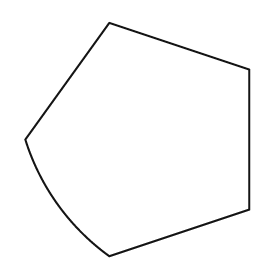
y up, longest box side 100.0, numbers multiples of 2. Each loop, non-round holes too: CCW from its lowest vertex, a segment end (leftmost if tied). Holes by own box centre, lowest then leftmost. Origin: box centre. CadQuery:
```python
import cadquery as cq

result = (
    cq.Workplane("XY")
    .moveTo(-12.0, -50.0)
    .lineTo(48.0, -30.0)
    .lineTo(48.0, 30.0)
    .lineTo(-12.0, 50.0)
    .lineTo(-48.0, 0.0)
    .threePointArc((-34.0, -28.0), (-12.0, -50.0))
    .close()
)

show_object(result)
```